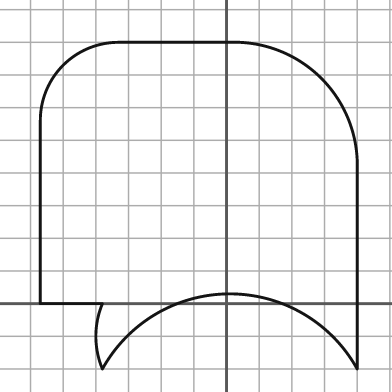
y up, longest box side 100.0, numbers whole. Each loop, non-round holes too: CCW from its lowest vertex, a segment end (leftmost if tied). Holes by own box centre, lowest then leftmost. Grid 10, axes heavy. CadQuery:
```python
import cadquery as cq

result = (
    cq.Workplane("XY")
    .moveTo(-38.0, -20.0)
    .threePointArc((1.0, 3.0), (40.0, -20.0))
    .lineTo(40.0, 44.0)
    .threePointArc((29.0, 69.0), (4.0, 80.0))
    .lineTo(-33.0, 80.0)
    .threePointArc((-50.0, 73.0), (-57.0, 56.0))
    .lineTo(-57.0, 0.0)
    .lineTo(-38.0, 0.0)
    .threePointArc((-40.0, -10.0), (-38.0, -20.0))
    .close()
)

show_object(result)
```